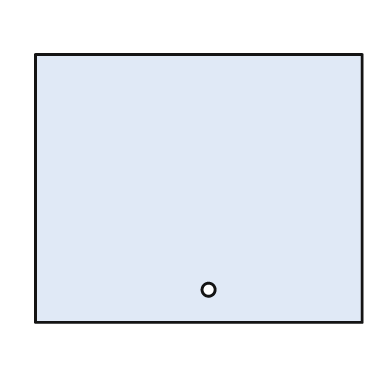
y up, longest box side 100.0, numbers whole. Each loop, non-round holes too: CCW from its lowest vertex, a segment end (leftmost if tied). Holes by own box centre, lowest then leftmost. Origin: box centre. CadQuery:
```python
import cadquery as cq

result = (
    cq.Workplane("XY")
    .moveTo(-50.0, -41.0)
    .lineTo(50.0, -41.0)
    .lineTo(50.0, 41.0)
    .lineTo(-50.0, 41.0)
    .close()
    .moveTo(3.0, -31.0)
    .circle(2.0)
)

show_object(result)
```